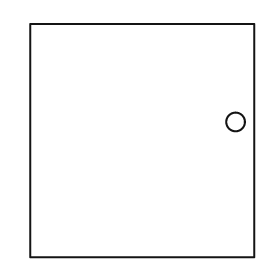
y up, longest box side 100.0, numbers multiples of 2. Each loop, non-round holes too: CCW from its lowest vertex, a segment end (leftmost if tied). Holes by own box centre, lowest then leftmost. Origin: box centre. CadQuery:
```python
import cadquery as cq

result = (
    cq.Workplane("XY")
    .moveTo(-48.0, -50.0)
    .lineTo(48.0, -50.0)
    .lineTo(48.0, 50.0)
    .lineTo(-48.0, 50.0)
    .close()
    .moveTo(40.0, 8.0)
    .circle(4.0)
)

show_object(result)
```